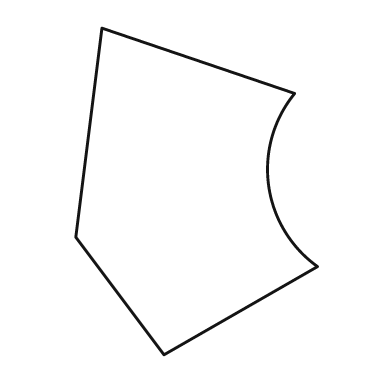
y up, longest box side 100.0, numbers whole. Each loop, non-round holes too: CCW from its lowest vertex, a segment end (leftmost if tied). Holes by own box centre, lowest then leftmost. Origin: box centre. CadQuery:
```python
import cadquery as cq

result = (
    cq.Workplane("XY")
    .moveTo(-10.0, -50.0)
    .lineTo(37.0, -23.0)
    .threePointArc((22.0, 2.0), (30.0, 30.0))
    .lineTo(-29.0, 50.0)
    .lineTo(-37.0, -14.0)
    .close()
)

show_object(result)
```